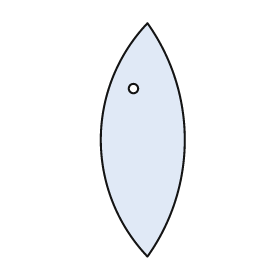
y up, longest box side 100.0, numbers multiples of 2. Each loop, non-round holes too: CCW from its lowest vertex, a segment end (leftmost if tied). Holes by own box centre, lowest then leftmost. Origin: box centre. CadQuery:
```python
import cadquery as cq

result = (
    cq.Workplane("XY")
    .moveTo(2.0, -50.0)
    .threePointArc((18.0, 0.0), (2.0, 50.0))
    .threePointArc((-18.0, 0.0), (2.0, -50.0))
    .close()
    .moveTo(-4.0, 22.0)
    .circle(2.0)
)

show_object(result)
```